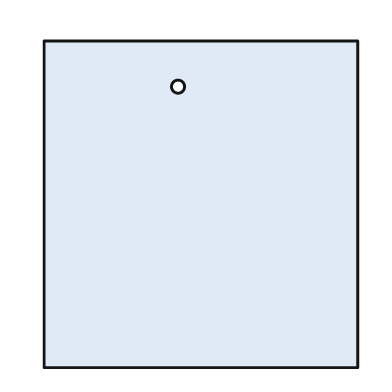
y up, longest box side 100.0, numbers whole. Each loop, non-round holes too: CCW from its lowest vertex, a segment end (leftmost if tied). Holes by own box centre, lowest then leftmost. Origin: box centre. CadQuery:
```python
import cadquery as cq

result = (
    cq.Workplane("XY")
    .moveTo(-48.0, -50.0)
    .lineTo(48.0, -50.0)
    .lineTo(48.0, 50.0)
    .lineTo(-48.0, 50.0)
    .close()
    .moveTo(-7.0, 36.0)
    .circle(2.0)
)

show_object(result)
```